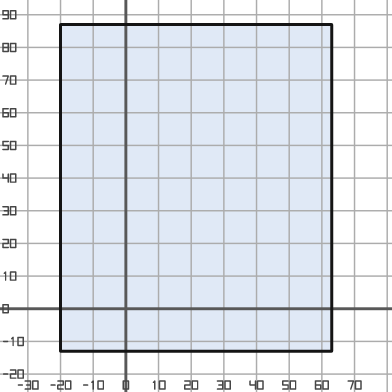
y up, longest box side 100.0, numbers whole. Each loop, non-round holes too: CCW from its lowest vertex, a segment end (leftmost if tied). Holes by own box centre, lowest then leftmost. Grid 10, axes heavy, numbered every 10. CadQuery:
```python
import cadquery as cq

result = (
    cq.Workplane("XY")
    .moveTo(-20.0, -13.0)
    .lineTo(63.0, -13.0)
    .lineTo(63.0, 87.0)
    .lineTo(-20.0, 87.0)
    .close()
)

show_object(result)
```